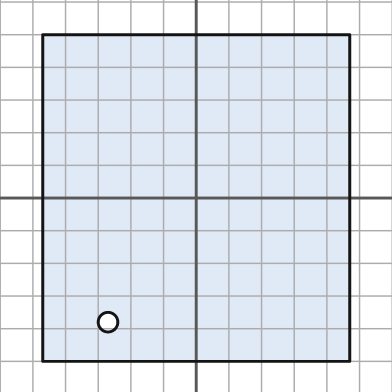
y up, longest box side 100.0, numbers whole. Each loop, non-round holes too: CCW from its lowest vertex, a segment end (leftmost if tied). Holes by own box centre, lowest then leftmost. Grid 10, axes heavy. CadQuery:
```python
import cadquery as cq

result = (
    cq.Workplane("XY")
    .moveTo(-47.0, -50.0)
    .lineTo(47.0, -50.0)
    .lineTo(47.0, 50.0)
    .lineTo(-47.0, 50.0)
    .close()
    .moveTo(-27.0, -38.0)
    .circle(3.0)
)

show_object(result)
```